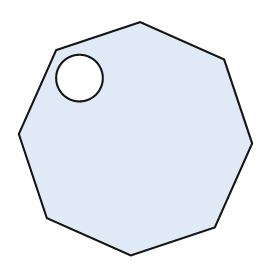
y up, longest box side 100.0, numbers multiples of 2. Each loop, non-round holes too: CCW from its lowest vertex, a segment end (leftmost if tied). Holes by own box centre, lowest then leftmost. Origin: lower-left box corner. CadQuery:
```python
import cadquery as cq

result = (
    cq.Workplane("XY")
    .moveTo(48.0, 0.0)
    .lineTo(84.0, 12.0)
    .lineTo(100.0, 48.0)
    .lineTo(88.0, 84.0)
    .lineTo(52.0, 100.0)
    .lineTo(16.0, 88.0)
    .lineTo(0.0, 52.0)
    .lineTo(12.0, 16.0)
    .close()
    .moveTo(26.0, 76.0)
    .circle(10.0)
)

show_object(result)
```